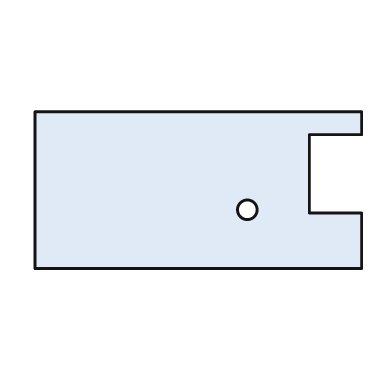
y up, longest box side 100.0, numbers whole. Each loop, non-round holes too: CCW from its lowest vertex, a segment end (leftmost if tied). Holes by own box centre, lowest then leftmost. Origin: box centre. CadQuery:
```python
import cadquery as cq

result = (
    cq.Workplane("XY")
    .moveTo(-50.0, -24.0)
    .lineTo(50.0, -24.0)
    .lineTo(50.0, -7.0)
    .lineTo(34.0, -7.0)
    .lineTo(34.0, 17.0)
    .lineTo(50.0, 17.0)
    .lineTo(50.0, 24.0)
    .lineTo(-50.0, 24.0)
    .close()
    .moveTo(15.0, -6.0)
    .circle(3.0)
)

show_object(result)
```